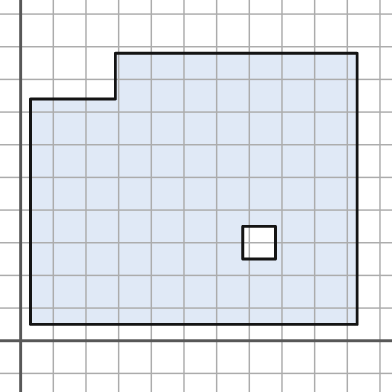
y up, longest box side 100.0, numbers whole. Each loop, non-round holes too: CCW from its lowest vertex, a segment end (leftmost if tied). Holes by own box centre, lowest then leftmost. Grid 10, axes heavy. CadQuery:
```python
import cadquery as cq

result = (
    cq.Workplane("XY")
    .moveTo(3.0, 5.0)
    .lineTo(103.0, 5.0)
    .lineTo(103.0, 88.0)
    .lineTo(29.0, 88.0)
    .lineTo(29.0, 74.0)
    .lineTo(3.0, 74.0)
    .close()
    .moveTo(68.0, 25.0)
    .lineTo(78.0, 25.0)
    .lineTo(78.0, 35.0)
    .lineTo(68.0, 35.0)
    .close()
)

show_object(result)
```